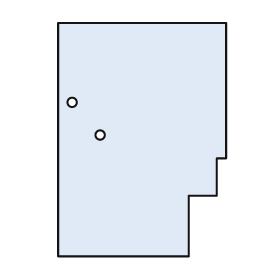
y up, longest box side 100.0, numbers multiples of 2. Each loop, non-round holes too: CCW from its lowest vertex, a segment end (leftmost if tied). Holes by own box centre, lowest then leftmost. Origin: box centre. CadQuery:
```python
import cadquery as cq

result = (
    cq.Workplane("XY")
    .moveTo(-36.0, -50.0)
    .lineTo(20.0, -50.0)
    .lineTo(20.0, -24.0)
    .lineTo(32.0, -24.0)
    .lineTo(32.0, -8.0)
    .lineTo(36.0, -8.0)
    .lineTo(36.0, 50.0)
    .lineTo(-36.0, 50.0)
    .close()
    .moveTo(-18.0, 2.0)
    .circle(2.0)
    .moveTo(-30.0, 16.0)
    .circle(2.0)
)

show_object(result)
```